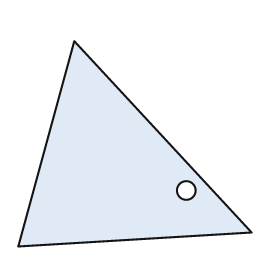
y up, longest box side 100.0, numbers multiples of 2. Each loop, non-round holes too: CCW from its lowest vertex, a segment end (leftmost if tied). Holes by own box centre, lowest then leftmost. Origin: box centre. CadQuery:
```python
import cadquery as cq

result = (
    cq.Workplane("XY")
    .moveTo(-50.0, -44.0)
    .lineTo(50.0, -38.0)
    .lineTo(-26.0, 44.0)
    .close()
    .moveTo(22.0, -20.0)
    .circle(4.0)
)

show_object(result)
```